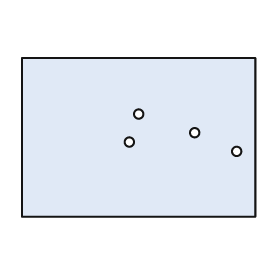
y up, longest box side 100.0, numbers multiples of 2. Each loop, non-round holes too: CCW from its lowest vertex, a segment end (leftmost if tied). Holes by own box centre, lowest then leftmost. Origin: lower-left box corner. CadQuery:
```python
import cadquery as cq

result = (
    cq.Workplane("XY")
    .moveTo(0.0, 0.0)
    .lineTo(100.0, 0.0)
    .lineTo(100.0, 68.0)
    .lineTo(0.0, 68.0)
    .close()
    .moveTo(92.0, 28.0)
    .circle(2.0)
    .moveTo(46.0, 32.0)
    .circle(2.0)
    .moveTo(74.0, 36.0)
    .circle(2.0)
    .moveTo(50.0, 44.0)
    .circle(2.0)
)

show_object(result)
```